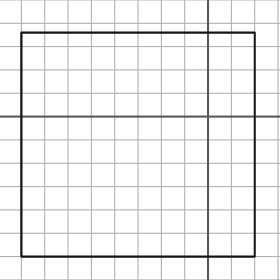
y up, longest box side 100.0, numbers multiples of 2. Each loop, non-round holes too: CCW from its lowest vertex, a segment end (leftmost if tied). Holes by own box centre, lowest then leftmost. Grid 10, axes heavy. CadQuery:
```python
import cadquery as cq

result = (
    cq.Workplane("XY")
    .moveTo(-80.0, -60.0)
    .lineTo(20.0, -60.0)
    .lineTo(20.0, 36.0)
    .lineTo(-80.0, 36.0)
    .close()
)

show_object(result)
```